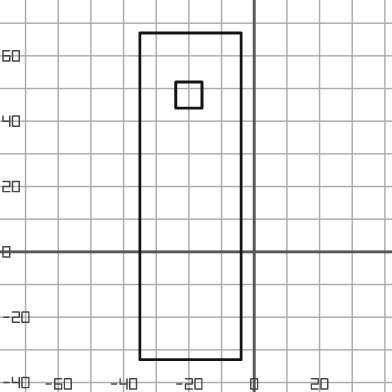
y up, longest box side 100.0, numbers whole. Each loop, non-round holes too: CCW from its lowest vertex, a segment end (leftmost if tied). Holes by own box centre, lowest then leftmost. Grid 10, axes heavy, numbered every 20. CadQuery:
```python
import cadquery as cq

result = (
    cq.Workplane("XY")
    .moveTo(-35.0, -33.0)
    .lineTo(-4.0, -33.0)
    .lineTo(-4.0, 67.0)
    .lineTo(-35.0, 67.0)
    .close()
    .moveTo(-24.0, 44.0)
    .lineTo(-16.0, 44.0)
    .lineTo(-16.0, 52.0)
    .lineTo(-24.0, 52.0)
    .close()
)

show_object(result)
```